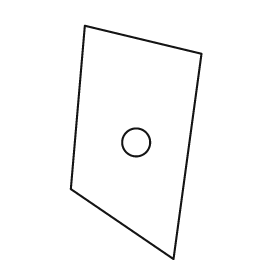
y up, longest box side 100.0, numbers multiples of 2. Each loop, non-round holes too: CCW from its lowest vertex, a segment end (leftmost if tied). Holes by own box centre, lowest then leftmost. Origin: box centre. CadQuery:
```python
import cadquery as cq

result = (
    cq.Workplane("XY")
    .moveTo(16.0, -50.0)
    .lineTo(28.0, 38.0)
    .lineTo(-22.0, 50.0)
    .lineTo(-28.0, -20.0)
    .close()
    .moveTo(0.0, 0.0)
    .circle(6.0)
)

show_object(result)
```